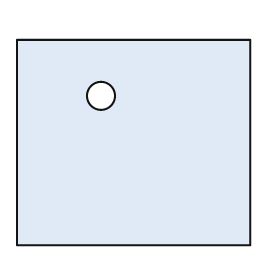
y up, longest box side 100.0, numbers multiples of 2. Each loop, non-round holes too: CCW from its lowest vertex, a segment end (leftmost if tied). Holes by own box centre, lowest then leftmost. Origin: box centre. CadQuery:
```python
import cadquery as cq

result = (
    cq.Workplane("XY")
    .moveTo(-50.0, -44.0)
    .lineTo(50.0, -44.0)
    .lineTo(50.0, 44.0)
    .lineTo(-50.0, 44.0)
    .close()
    .moveTo(-14.0, 20.0)
    .circle(6.0)
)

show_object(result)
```